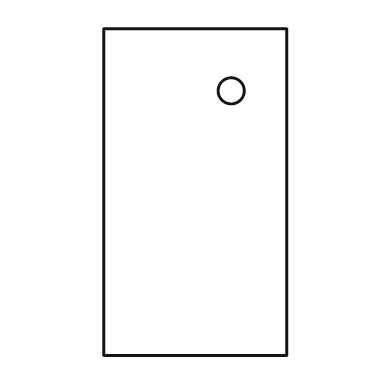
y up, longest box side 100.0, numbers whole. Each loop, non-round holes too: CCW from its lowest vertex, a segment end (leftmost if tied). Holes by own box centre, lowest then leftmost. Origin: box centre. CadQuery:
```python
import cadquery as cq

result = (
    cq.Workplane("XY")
    .moveTo(-28.0, -50.0)
    .lineTo(28.0, -50.0)
    .lineTo(28.0, 50.0)
    .lineTo(-28.0, 50.0)
    .close()
    .moveTo(11.0, 31.0)
    .circle(4.0)
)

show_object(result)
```